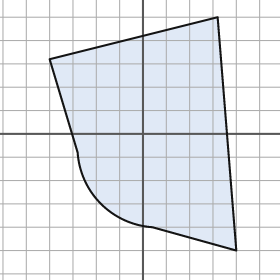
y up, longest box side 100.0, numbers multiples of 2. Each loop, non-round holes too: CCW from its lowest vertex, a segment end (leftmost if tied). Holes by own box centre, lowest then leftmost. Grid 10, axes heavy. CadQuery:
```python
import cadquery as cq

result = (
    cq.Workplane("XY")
    .moveTo(40.0, -50.0)
    .lineTo(32.0, 50.0)
    .lineTo(-40.0, 32.0)
    .lineTo(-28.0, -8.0)
    .threePointArc((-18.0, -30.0), (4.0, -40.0))
    .close()
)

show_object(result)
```